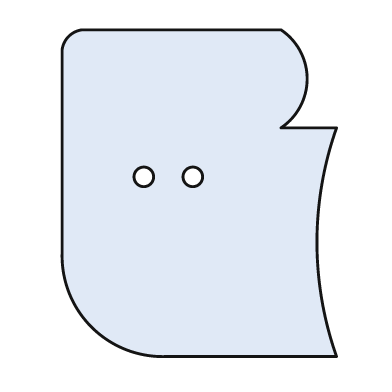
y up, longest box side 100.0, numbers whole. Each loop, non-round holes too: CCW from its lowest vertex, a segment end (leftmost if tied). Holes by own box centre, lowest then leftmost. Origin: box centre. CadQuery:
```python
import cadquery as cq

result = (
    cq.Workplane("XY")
    .moveTo(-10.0, -50.0)
    .lineTo(42.0, -50.0)
    .threePointArc((36.0, -15.0), (42.0, 20.0))
    .lineTo(25.0, 20.0)
    .threePointArc((33.0, 35.0), (25.0, 50.0))
    .lineTo(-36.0, 50.0)
    .threePointArc((-40.0, 48.0), (-42.0, 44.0))
    .lineTo(-42.0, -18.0)
    .threePointArc((-33.0, -41.0), (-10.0, -50.0))
    .close()
    .moveTo(-17.0, 5.0)
    .circle(3.0)
    .moveTo(-2.0, 5.0)
    .circle(3.0)
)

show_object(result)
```